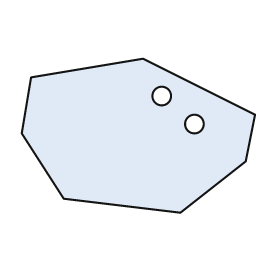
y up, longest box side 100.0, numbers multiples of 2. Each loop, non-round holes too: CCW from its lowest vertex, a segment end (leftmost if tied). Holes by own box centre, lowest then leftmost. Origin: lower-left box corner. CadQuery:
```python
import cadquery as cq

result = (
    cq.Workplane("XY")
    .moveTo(68.0, 0.0)
    .lineTo(96.0, 22.0)
    .lineTo(100.0, 42.0)
    .lineTo(52.0, 66.0)
    .lineTo(4.0, 58.0)
    .lineTo(0.0, 34.0)
    .lineTo(18.0, 6.0)
    .close()
    .moveTo(74.0, 38.0)
    .circle(4.0)
    .moveTo(60.0, 50.0)
    .circle(4.0)
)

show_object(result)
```